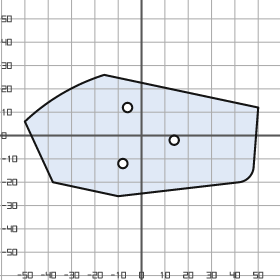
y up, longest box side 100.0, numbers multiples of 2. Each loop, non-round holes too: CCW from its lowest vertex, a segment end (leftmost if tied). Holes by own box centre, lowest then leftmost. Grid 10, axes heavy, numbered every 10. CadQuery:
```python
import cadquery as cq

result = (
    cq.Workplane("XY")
    .moveTo(-10.0, -26.0)
    .lineTo(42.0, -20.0)
    .threePointArc((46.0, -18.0), (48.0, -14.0))
    .lineTo(50.0, 12.0)
    .lineTo(-16.0, 26.0)
    .threePointArc((-34.0, 18.0), (-50.0, 6.0))
    .lineTo(-38.0, -20.0)
    .close()
    .moveTo(-8.0, -12.0)
    .circle(2.0)
    .moveTo(14.0, -2.0)
    .circle(2.0)
    .moveTo(-6.0, 12.0)
    .circle(2.0)
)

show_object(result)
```